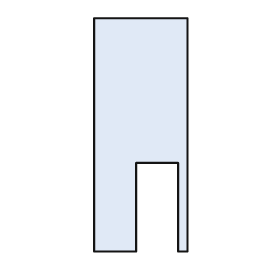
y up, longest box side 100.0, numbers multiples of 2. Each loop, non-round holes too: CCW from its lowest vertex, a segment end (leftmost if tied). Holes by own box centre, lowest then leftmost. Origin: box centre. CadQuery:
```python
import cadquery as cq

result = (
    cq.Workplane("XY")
    .moveTo(-20.0, -50.0)
    .lineTo(-2.0, -50.0)
    .lineTo(-2.0, -12.0)
    .lineTo(16.0, -12.0)
    .lineTo(16.0, -50.0)
    .lineTo(20.0, -50.0)
    .lineTo(20.0, 50.0)
    .lineTo(-20.0, 50.0)
    .close()
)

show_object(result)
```